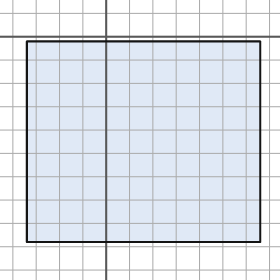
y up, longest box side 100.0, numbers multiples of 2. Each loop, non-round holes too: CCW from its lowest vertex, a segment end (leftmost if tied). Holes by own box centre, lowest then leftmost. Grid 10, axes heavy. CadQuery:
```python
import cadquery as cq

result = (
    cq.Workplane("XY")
    .moveTo(-34.0, -88.0)
    .lineTo(66.0, -88.0)
    .lineTo(66.0, -2.0)
    .lineTo(-34.0, -2.0)
    .close()
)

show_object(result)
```